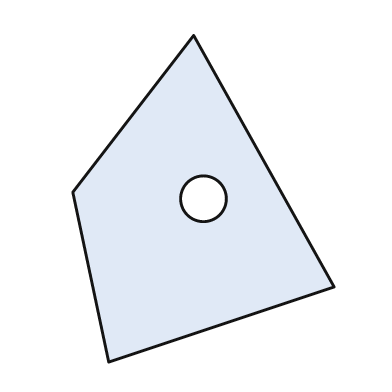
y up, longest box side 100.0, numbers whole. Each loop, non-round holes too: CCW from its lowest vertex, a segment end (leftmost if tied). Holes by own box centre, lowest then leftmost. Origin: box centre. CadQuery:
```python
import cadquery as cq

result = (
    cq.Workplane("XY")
    .moveTo(-29.0, -50.0)
    .lineTo(40.0, -27.0)
    .lineTo(-3.0, 50.0)
    .lineTo(-40.0, 2.0)
    .close()
    .moveTo(0.0, 0.0)
    .circle(7.0)
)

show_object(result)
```